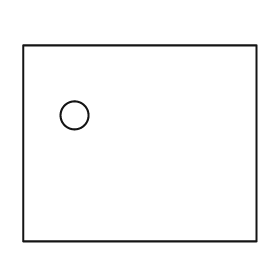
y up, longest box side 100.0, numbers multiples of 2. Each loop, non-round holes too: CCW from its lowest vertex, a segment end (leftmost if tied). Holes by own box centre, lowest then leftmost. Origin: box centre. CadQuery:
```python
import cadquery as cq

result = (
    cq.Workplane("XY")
    .moveTo(-50.0, -42.0)
    .lineTo(50.0, -42.0)
    .lineTo(50.0, 42.0)
    .lineTo(-50.0, 42.0)
    .close()
    .moveTo(-28.0, 12.0)
    .circle(6.0)
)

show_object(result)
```